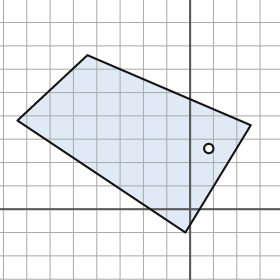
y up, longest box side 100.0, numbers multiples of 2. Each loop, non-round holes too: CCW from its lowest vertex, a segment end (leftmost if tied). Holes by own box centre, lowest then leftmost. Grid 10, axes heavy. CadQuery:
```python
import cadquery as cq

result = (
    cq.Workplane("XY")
    .moveTo(-2.0, -10.0)
    .lineTo(26.0, 36.0)
    .lineTo(-44.0, 66.0)
    .lineTo(-74.0, 38.0)
    .close()
    .moveTo(8.0, 26.0)
    .circle(2.0)
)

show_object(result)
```